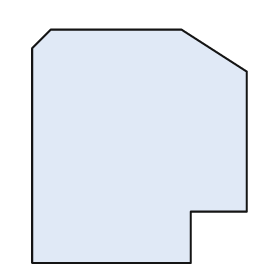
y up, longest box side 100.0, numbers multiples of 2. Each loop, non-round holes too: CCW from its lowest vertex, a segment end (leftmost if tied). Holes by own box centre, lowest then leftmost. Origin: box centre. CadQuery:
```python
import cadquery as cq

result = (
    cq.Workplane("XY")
    .moveTo(-46.0, -50.0)
    .lineTo(22.0, -50.0)
    .lineTo(22.0, -28.0)
    .lineTo(46.0, -28.0)
    .lineTo(46.0, 32.0)
    .lineTo(18.0, 50.0)
    .lineTo(-38.0, 50.0)
    .lineTo(-46.0, 42.0)
    .close()
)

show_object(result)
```